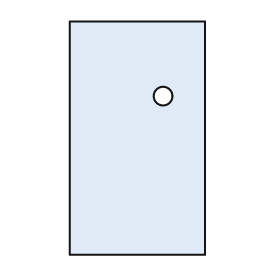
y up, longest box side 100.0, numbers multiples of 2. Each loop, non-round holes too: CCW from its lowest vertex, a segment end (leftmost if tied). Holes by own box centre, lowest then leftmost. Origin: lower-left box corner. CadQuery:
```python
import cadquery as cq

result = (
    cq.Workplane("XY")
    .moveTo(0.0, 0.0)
    .lineTo(58.0, 0.0)
    .lineTo(58.0, 100.0)
    .lineTo(0.0, 100.0)
    .close()
    .moveTo(40.0, 68.0)
    .circle(4.0)
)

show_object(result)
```